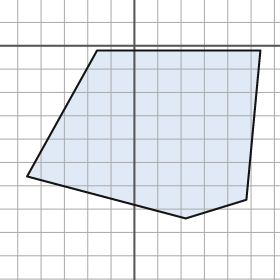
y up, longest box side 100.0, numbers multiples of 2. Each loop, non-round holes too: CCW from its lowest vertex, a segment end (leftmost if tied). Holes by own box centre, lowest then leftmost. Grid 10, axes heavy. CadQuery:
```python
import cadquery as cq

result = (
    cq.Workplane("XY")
    .moveTo(22.0, -74.0)
    .lineTo(48.0, -66.0)
    .lineTo(54.0, -2.0)
    .lineTo(-16.0, -2.0)
    .lineTo(-46.0, -56.0)
    .close()
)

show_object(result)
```